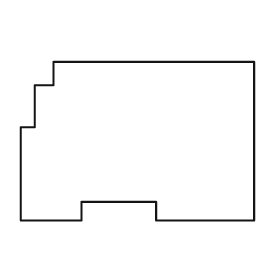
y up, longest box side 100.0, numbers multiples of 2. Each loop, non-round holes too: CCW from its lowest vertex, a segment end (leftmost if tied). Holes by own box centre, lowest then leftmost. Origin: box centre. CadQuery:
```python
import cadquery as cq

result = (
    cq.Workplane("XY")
    .moveTo(-50.0, -34.0)
    .lineTo(-24.0, -34.0)
    .lineTo(-24.0, -26.0)
    .lineTo(8.0, -26.0)
    .lineTo(8.0, -34.0)
    .lineTo(50.0, -34.0)
    .lineTo(50.0, 34.0)
    .lineTo(-36.0, 34.0)
    .lineTo(-36.0, 24.0)
    .lineTo(-44.0, 24.0)
    .lineTo(-44.0, 6.0)
    .lineTo(-50.0, 6.0)
    .close()
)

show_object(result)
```